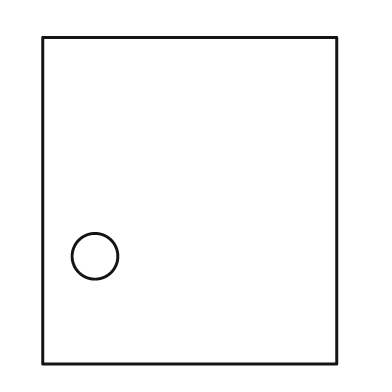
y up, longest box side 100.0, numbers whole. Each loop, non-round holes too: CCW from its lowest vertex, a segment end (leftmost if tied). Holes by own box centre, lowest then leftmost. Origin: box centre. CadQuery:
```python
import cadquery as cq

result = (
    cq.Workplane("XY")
    .moveTo(-45.0, -50.0)
    .lineTo(45.0, -50.0)
    .lineTo(45.0, 50.0)
    .lineTo(-45.0, 50.0)
    .close()
    .moveTo(-29.0, -17.0)
    .circle(7.0)
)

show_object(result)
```